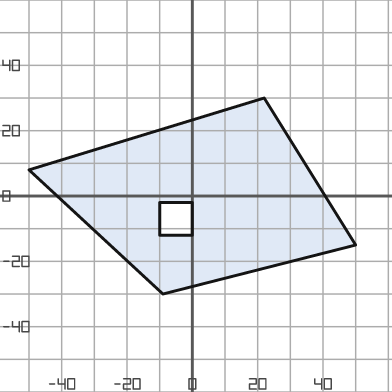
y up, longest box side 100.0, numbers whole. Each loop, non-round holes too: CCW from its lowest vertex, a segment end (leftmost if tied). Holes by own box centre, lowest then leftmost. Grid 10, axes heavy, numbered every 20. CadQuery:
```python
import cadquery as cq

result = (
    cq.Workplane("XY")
    .moveTo(-9.0, -30.0)
    .lineTo(50.0, -15.0)
    .lineTo(22.0, 30.0)
    .lineTo(-50.0, 8.0)
    .close()
    .moveTo(-10.0, -12.0)
    .lineTo(0.0, -12.0)
    .lineTo(0.0, -2.0)
    .lineTo(-10.0, -2.0)
    .close()
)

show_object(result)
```